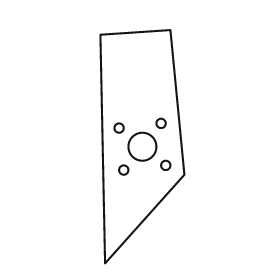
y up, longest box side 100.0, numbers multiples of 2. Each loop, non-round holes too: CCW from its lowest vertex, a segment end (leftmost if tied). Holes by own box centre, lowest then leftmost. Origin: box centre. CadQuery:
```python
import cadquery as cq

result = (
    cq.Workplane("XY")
    .moveTo(-16.0, -50.0)
    .lineTo(18.0, -12.0)
    .lineTo(12.0, 50.0)
    .lineTo(-18.0, 48.0)
    .close()
    .moveTo(-8.0, -10.0)
    .circle(2.0)
    .moveTo(10.0, -8.0)
    .circle(2.0)
    .moveTo(0.0, 0.0)
    .circle(6.0)
    .moveTo(-10.0, 8.0)
    .circle(2.0)
    .moveTo(8.0, 10.0)
    .circle(2.0)
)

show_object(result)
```